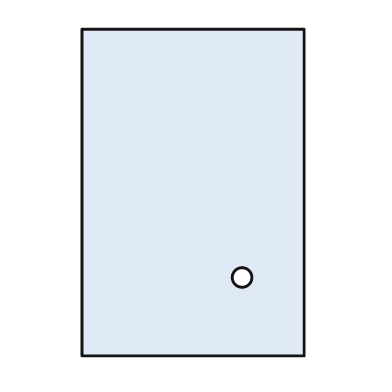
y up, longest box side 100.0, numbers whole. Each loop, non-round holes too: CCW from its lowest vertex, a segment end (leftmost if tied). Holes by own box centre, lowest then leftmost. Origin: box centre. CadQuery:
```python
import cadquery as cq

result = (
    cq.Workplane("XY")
    .moveTo(-34.0, -50.0)
    .lineTo(34.0, -50.0)
    .lineTo(34.0, 50.0)
    .lineTo(-34.0, 50.0)
    .close()
    .moveTo(15.0, -26.0)
    .circle(3.0)
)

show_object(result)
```